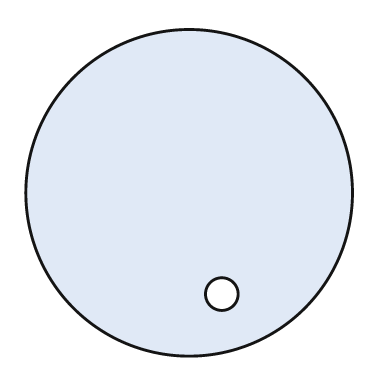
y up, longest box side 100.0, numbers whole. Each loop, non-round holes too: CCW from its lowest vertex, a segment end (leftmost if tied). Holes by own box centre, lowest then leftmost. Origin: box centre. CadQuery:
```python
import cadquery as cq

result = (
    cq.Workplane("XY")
    .moveTo(0.0, 0.0)
    .circle(50.0)
    .moveTo(10.0, -31.0)
    .circle(5.0)
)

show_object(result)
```